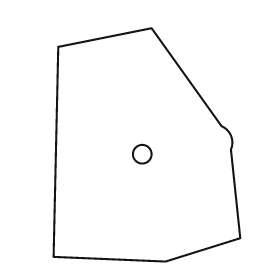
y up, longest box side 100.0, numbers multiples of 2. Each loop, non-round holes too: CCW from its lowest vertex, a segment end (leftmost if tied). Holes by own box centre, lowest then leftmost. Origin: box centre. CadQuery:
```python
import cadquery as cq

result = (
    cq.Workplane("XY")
    .moveTo(8.0, -50.0)
    .lineTo(40.0, -40.0)
    .lineTo(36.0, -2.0)
    .threePointArc((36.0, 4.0), (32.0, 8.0))
    .lineTo(2.0, 50.0)
    .lineTo(-38.0, 42.0)
    .lineTo(-40.0, -48.0)
    .close()
    .moveTo(-2.0, -4.0)
    .circle(4.0)
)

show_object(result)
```